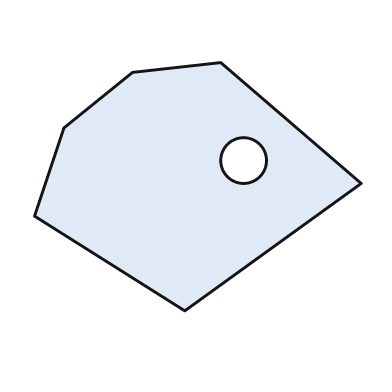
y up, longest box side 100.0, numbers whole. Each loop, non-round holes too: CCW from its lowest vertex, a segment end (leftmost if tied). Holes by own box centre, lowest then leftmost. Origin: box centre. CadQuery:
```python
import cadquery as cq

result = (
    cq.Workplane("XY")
    .moveTo(-4.0, -38.0)
    .lineTo(50.0, 1.0)
    .lineTo(7.0, 38.0)
    .lineTo(-20.0, 35.0)
    .lineTo(-41.0, 18.0)
    .lineTo(-50.0, -9.0)
    .close()
    .moveTo(14.0, 8.0)
    .circle(7.0)
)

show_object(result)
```